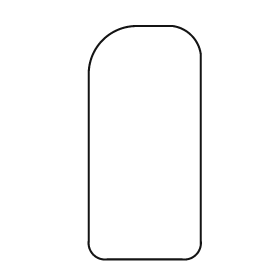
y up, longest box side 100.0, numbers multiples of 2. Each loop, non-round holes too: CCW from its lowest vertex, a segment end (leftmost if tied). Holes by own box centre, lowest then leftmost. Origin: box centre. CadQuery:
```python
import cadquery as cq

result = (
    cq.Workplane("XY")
    .moveTo(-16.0, -50.0)
    .lineTo(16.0, -50.0)
    .threePointArc((22.0, -48.0), (24.0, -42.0))
    .lineTo(24.0, 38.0)
    .threePointArc((20.0, 46.0), (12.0, 50.0))
    .lineTo(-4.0, 50.0)
    .threePointArc((-18.0, 44.0), (-24.0, 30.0))
    .lineTo(-24.0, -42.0)
    .threePointArc((-22.0, -48.0), (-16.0, -50.0))
    .close()
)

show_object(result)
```